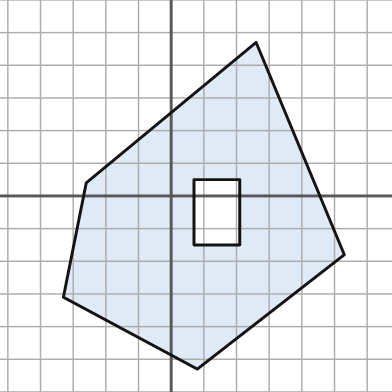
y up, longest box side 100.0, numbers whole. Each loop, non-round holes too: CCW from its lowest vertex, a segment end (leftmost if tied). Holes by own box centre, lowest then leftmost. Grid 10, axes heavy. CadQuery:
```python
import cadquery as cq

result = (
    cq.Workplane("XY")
    .moveTo(8.0, -53.0)
    .lineTo(53.0, -18.0)
    .lineTo(26.0, 47.0)
    .lineTo(-26.0, 4.0)
    .lineTo(-33.0, -31.0)
    .close()
    .moveTo(7.0, -15.0)
    .lineTo(21.0, -15.0)
    .lineTo(21.0, 5.0)
    .lineTo(7.0, 5.0)
    .close()
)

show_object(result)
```